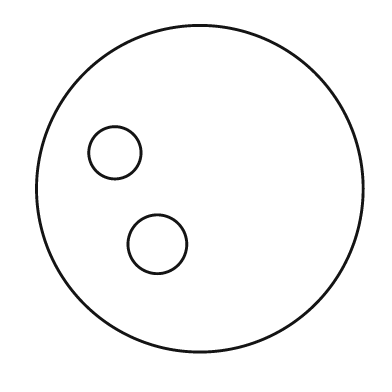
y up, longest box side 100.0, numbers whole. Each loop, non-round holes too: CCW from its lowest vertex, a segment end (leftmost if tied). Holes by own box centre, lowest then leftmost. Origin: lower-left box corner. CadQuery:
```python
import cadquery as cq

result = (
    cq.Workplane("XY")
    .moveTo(50.0, 50.0)
    .circle(50.0)
    .moveTo(37.0, 33.0)
    .circle(9.0)
    .moveTo(24.0, 61.0)
    .circle(8.0)
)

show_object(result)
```